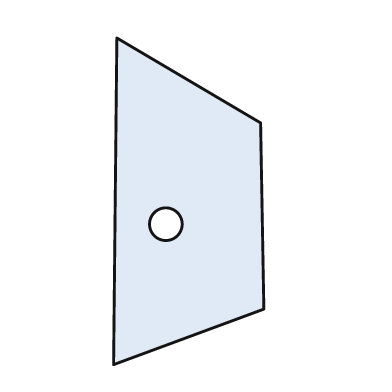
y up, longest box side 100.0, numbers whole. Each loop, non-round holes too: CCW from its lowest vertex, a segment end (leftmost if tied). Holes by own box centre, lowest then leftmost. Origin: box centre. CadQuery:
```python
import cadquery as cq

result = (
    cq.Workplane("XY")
    .moveTo(-23.0, -50.0)
    .lineTo(23.0, -33.0)
    .lineTo(22.0, 24.0)
    .lineTo(-22.0, 50.0)
    .close()
    .moveTo(-7.0, -7.0)
    .circle(5.0)
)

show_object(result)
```